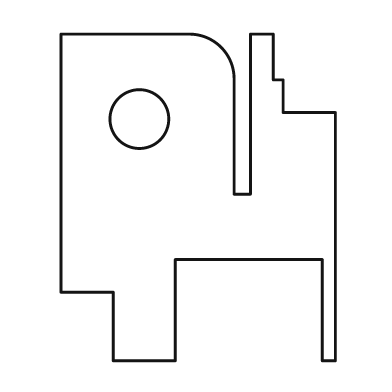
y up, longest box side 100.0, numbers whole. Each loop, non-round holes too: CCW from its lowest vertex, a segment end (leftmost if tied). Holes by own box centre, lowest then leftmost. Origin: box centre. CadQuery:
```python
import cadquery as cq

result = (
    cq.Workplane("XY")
    .moveTo(-26.0, -50.0)
    .lineTo(-7.0, -50.0)
    .lineTo(-7.0, -19.0)
    .lineTo(38.0, -19.0)
    .lineTo(38.0, -50.0)
    .lineTo(42.0, -50.0)
    .lineTo(42.0, 26.0)
    .lineTo(26.0, 26.0)
    .lineTo(26.0, 36.0)
    .lineTo(23.0, 36.0)
    .lineTo(23.0, 50.0)
    .lineTo(16.0, 50.0)
    .lineTo(16.0, 1.0)
    .lineTo(11.0, 1.0)
    .lineTo(11.0, 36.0)
    .threePointArc((7.0, 46.0), (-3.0, 50.0))
    .lineTo(-42.0, 50.0)
    .lineTo(-42.0, -29.0)
    .lineTo(-26.0, -29.0)
    .close()
    .moveTo(-18.0, 24.0)
    .circle(9.0)
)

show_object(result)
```